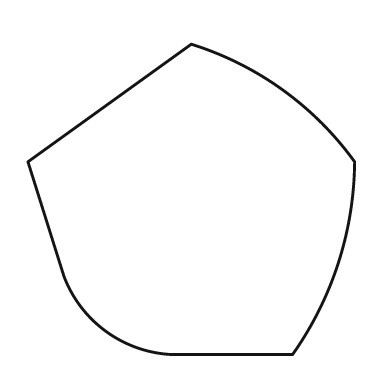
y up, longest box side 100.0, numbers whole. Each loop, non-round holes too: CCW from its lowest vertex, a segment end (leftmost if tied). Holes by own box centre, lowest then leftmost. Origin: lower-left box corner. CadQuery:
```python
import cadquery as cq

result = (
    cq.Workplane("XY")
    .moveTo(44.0, 0.0)
    .lineTo(81.0, 0.0)
    .threePointArc((95.0, 28.0), (100.0, 59.0))
    .threePointArc((78.0, 81.0), (50.0, 95.0))
    .lineTo(0.0, 59.0)
    .lineTo(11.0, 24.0)
    .threePointArc((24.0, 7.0), (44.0, 0.0))
    .close()
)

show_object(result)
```